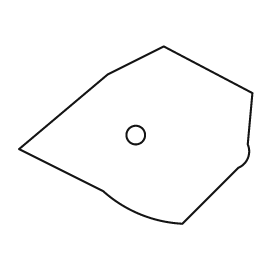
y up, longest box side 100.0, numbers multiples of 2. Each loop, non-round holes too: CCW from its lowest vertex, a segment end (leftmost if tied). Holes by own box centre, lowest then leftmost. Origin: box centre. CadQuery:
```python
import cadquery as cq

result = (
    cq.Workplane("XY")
    .moveTo(20.0, -38.0)
    .lineTo(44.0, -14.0)
    .threePointArc((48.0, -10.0), (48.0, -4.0))
    .lineTo(50.0, 18.0)
    .lineTo(12.0, 38.0)
    .lineTo(-12.0, 26.0)
    .lineTo(-50.0, -6.0)
    .lineTo(-14.0, -24.0)
    .threePointArc((2.0, -34.0), (20.0, -38.0))
    .close()
    .moveTo(0.0, 0.0)
    .circle(4.0)
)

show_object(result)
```